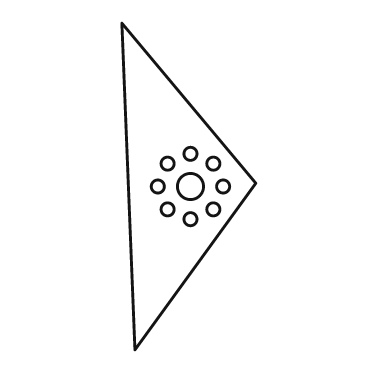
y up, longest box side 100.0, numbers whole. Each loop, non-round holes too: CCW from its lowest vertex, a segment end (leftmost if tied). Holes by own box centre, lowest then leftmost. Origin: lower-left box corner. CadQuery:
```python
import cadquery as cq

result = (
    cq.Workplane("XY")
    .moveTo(4.0, 0.0)
    .lineTo(41.0, 51.0)
    .lineTo(0.0, 100.0)
    .close()
    .moveTo(21.0, 40.0)
    .circle(2.0)
    .moveTo(14.0, 43.0)
    .circle(2.0)
    .moveTo(28.0, 43.0)
    .circle(2.0)
    .moveTo(11.0, 50.0)
    .circle(2.0)
    .moveTo(21.0, 50.0)
    .circle(4.0)
    .moveTo(31.0, 50.0)
    .circle(2.0)
    .moveTo(14.0, 57.0)
    .circle(2.0)
    .moveTo(28.0, 57.0)
    .circle(2.0)
    .moveTo(21.0, 60.0)
    .circle(2.0)
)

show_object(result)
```